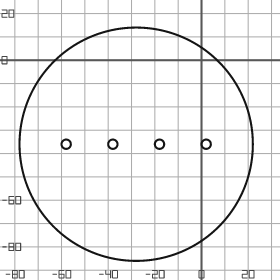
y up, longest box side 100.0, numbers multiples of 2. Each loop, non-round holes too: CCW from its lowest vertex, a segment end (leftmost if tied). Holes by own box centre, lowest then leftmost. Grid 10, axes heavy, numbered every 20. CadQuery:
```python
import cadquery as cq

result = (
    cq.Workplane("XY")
    .moveTo(-28.0, -36.0)
    .circle(50.0)
    .moveTo(-58.0, -36.0)
    .circle(2.0)
    .moveTo(-38.0, -36.0)
    .circle(2.0)
    .moveTo(-18.0, -36.0)
    .circle(2.0)
    .moveTo(2.0, -36.0)
    .circle(2.0)
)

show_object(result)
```